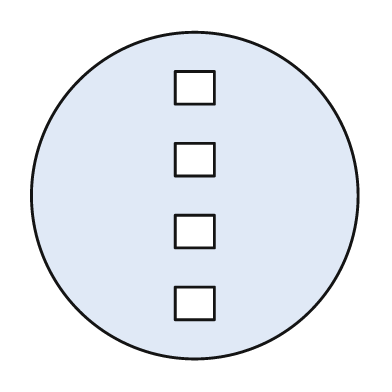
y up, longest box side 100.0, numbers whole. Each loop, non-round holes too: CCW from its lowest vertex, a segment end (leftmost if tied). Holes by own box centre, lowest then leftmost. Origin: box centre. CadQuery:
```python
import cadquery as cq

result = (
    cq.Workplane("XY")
    .moveTo(0.0, 0.0)
    .circle(50.0)
    .moveTo(-6.0, -38.0)
    .lineTo(6.0, -38.0)
    .lineTo(6.0, -28.0)
    .lineTo(-6.0, -28.0)
    .close()
    .moveTo(-6.0, -16.0)
    .lineTo(6.0, -16.0)
    .lineTo(6.0, -6.0)
    .lineTo(-6.0, -6.0)
    .close()
    .moveTo(-6.0, 6.0)
    .lineTo(6.0, 6.0)
    .lineTo(6.0, 16.0)
    .lineTo(-6.0, 16.0)
    .close()
    .moveTo(-6.0, 28.0)
    .lineTo(6.0, 28.0)
    .lineTo(6.0, 38.0)
    .lineTo(-6.0, 38.0)
    .close()
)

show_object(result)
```